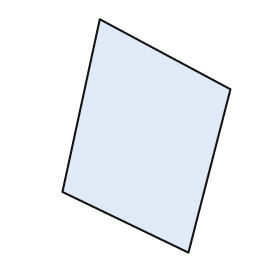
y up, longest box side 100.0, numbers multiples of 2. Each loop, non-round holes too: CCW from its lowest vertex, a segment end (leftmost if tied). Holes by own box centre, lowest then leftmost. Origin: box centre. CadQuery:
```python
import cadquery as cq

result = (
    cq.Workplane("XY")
    .moveTo(18.0, -50.0)
    .lineTo(36.0, 20.0)
    .lineTo(-20.0, 50.0)
    .lineTo(-36.0, -24.0)
    .close()
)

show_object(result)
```